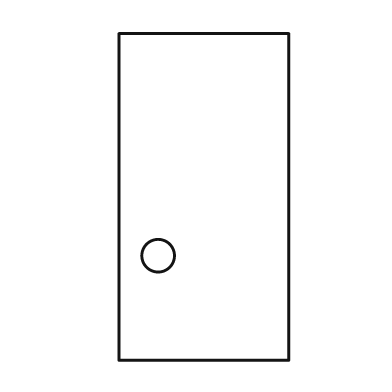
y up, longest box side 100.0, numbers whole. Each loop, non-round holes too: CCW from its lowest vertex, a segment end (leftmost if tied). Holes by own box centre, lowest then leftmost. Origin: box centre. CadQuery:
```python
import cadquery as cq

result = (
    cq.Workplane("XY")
    .moveTo(-26.0, -50.0)
    .lineTo(26.0, -50.0)
    .lineTo(26.0, 50.0)
    .lineTo(-26.0, 50.0)
    .close()
    .moveTo(-14.0, -18.0)
    .circle(5.0)
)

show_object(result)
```